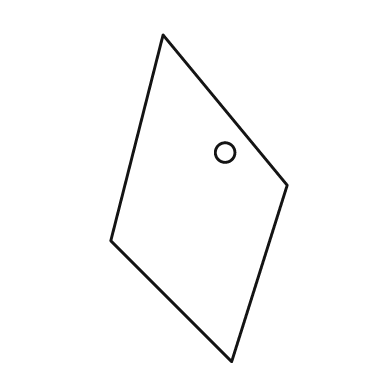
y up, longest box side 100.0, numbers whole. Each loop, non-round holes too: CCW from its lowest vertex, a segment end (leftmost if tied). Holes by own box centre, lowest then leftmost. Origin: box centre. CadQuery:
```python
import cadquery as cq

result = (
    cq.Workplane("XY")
    .moveTo(10.0, -50.0)
    .lineTo(27.0, 4.0)
    .lineTo(-11.0, 50.0)
    .lineTo(-27.0, -13.0)
    .close()
    .moveTo(8.0, 14.0)
    .circle(3.0)
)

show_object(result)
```